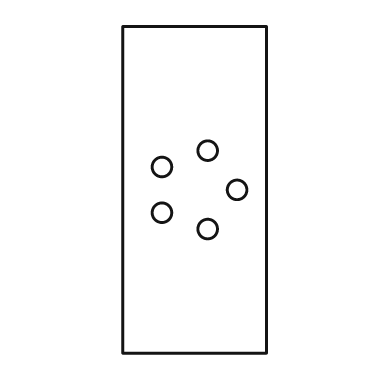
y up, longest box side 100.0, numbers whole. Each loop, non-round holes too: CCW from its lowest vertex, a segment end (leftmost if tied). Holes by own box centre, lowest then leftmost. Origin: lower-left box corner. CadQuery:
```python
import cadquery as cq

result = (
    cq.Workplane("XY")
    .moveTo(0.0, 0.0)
    .lineTo(44.0, 0.0)
    .lineTo(44.0, 100.0)
    .lineTo(0.0, 100.0)
    .close()
    .moveTo(26.0, 38.0)
    .circle(3.0)
    .moveTo(12.0, 43.0)
    .circle(3.0)
    .moveTo(35.0, 50.0)
    .circle(3.0)
    .moveTo(12.0, 57.0)
    .circle(3.0)
    .moveTo(26.0, 62.0)
    .circle(3.0)
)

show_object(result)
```